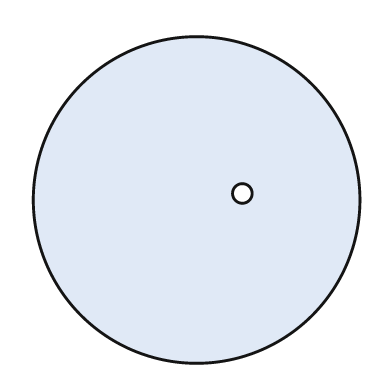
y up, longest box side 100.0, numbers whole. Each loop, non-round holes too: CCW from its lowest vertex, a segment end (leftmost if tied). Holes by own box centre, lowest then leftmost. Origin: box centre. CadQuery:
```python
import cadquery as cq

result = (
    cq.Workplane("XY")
    .moveTo(0.0, 0.0)
    .circle(50.0)
    .moveTo(14.0, 2.0)
    .circle(3.0)
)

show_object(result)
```